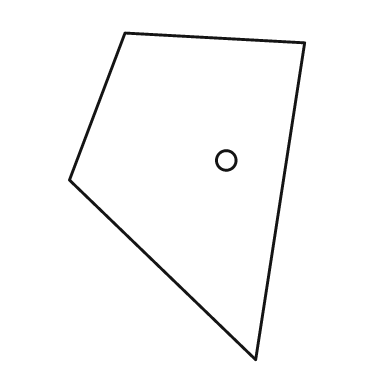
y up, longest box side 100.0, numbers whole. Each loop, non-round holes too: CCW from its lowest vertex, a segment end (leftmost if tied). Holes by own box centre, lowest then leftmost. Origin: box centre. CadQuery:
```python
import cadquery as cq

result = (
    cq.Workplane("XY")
    .moveTo(21.0, -50.0)
    .lineTo(36.0, 47.0)
    .lineTo(-19.0, 50.0)
    .lineTo(-36.0, 5.0)
    .close()
    .moveTo(12.0, 11.0)
    .circle(3.0)
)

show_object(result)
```